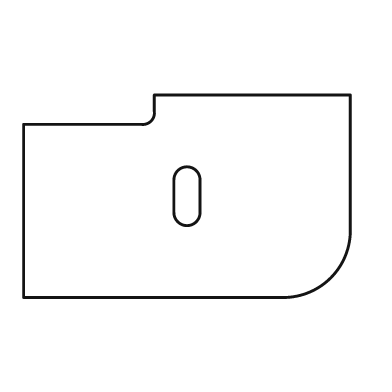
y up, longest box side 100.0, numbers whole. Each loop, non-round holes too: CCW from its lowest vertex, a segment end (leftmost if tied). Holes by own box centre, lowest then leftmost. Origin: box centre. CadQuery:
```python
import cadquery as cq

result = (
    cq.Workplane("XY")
    .moveTo(-50.0, -31.0)
    .lineTo(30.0, -31.0)
    .threePointArc((44.0, -25.0), (50.0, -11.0))
    .lineTo(50.0, 31.0)
    .lineTo(-10.0, 31.0)
    .lineTo(-10.0, 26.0)
    .threePointArc((-11.0, 23.0), (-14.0, 22.0))
    .lineTo(-50.0, 22.0)
    .close()
    .moveTo(-4.0, -5.0)
    .threePointArc((0.0, -9.0), (4.0, -5.0))
    .lineTo(4.0, 5.0)
    .threePointArc((0.0, 9.0), (-4.0, 5.0))
    .close()
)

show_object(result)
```